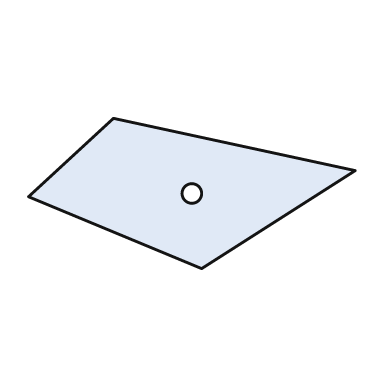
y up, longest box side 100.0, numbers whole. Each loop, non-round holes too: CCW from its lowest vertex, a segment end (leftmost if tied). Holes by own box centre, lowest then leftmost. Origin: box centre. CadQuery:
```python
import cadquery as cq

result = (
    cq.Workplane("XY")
    .moveTo(3.0, -23.0)
    .lineTo(50.0, 7.0)
    .lineTo(-24.0, 23.0)
    .lineTo(-50.0, -1.0)
    .close()
    .moveTo(0.0, 0.0)
    .circle(3.0)
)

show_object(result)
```